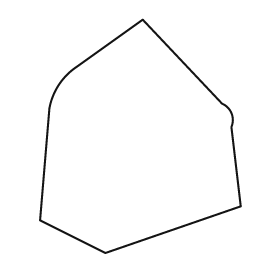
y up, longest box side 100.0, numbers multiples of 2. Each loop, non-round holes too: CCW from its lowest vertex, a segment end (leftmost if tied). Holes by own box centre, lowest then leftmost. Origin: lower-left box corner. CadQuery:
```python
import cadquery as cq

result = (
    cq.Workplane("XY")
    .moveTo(28.0, 0.0)
    .lineTo(86.0, 20.0)
    .lineTo(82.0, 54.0)
    .threePointArc((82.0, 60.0), (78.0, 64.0))
    .lineTo(44.0, 100.0)
    .lineTo(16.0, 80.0)
    .threePointArc((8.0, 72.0), (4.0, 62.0))
    .lineTo(0.0, 14.0)
    .close()
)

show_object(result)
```